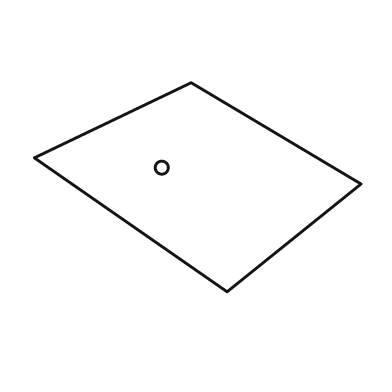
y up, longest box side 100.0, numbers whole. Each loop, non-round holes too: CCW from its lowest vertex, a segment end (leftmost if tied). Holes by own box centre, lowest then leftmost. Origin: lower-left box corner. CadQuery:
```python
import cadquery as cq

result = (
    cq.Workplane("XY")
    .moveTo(59.0, 0.0)
    .lineTo(100.0, 33.0)
    .lineTo(48.0, 64.0)
    .lineTo(0.0, 41.0)
    .close()
    .moveTo(39.0, 38.0)
    .circle(2.0)
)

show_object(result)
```